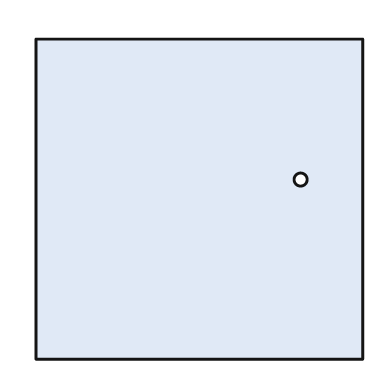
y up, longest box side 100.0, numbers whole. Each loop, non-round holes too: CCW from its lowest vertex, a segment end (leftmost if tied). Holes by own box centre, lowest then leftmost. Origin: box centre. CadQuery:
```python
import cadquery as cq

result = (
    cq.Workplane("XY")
    .moveTo(-50.0, -49.0)
    .lineTo(50.0, -49.0)
    .lineTo(50.0, 49.0)
    .lineTo(-50.0, 49.0)
    .close()
    .moveTo(31.0, 6.0)
    .circle(2.0)
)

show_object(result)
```